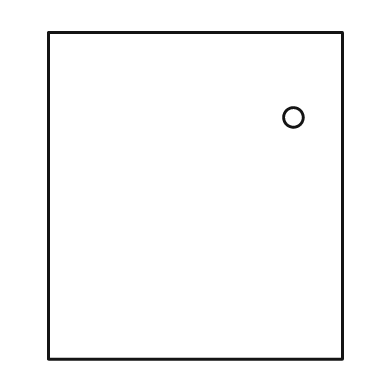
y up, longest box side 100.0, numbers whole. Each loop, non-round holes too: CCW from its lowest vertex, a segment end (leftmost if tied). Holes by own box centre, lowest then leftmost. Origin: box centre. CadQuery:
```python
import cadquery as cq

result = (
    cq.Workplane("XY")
    .moveTo(-45.0, -50.0)
    .lineTo(45.0, -50.0)
    .lineTo(45.0, 50.0)
    .lineTo(-45.0, 50.0)
    .close()
    .moveTo(30.0, 24.0)
    .circle(3.0)
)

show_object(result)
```